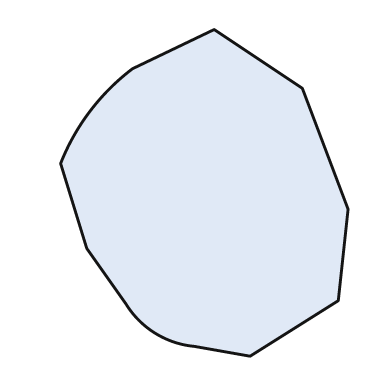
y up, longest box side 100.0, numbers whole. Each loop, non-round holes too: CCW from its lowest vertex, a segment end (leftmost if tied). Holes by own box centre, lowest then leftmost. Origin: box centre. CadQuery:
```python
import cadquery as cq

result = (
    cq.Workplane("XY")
    .moveTo(14.0, -50.0)
    .lineTo(41.0, -33.0)
    .lineTo(44.0, -5.0)
    .lineTo(30.0, 32.0)
    .lineTo(3.0, 50.0)
    .lineTo(-22.0, 38.0)
    .threePointArc((-35.0, 25.0), (-44.0, 9.0))
    .lineTo(-36.0, -17.0)
    .lineTo(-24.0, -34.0)
    .threePointArc((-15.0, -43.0), (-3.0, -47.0))
    .close()
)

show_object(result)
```